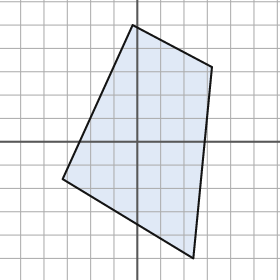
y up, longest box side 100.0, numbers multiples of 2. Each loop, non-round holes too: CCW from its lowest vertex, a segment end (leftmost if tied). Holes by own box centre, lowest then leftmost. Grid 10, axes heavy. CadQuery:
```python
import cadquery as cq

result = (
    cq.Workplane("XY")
    .moveTo(24.0, -50.0)
    .lineTo(32.0, 32.0)
    .lineTo(-2.0, 50.0)
    .lineTo(-32.0, -16.0)
    .close()
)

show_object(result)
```